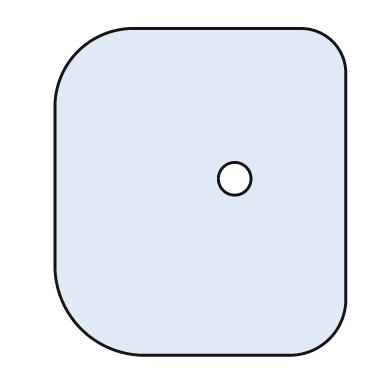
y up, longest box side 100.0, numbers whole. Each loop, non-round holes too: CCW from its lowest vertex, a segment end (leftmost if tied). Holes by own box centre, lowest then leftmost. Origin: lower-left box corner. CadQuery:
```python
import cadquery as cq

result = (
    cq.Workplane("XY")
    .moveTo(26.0, 0.0)
    .lineTo(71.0, 0.0)
    .threePointArc((84.0, 5.0), (89.0, 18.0))
    .lineTo(89.0, 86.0)
    .threePointArc((85.0, 96.0), (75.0, 100.0))
    .lineTo(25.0, 100.0)
    .threePointArc((7.0, 93.0), (0.0, 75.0))
    .lineTo(0.0, 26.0)
    .threePointArc((8.0, 8.0), (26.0, 0.0))
    .close()
    .moveTo(55.0, 54.0)
    .circle(5.0)
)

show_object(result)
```